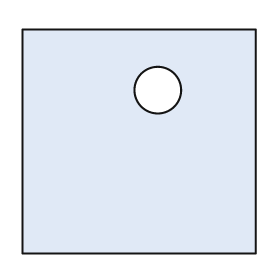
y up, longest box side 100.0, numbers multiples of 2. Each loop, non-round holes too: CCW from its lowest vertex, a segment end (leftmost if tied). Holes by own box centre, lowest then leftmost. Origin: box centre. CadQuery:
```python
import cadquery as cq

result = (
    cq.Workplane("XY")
    .moveTo(-50.0, -48.0)
    .lineTo(50.0, -48.0)
    .lineTo(50.0, 48.0)
    .lineTo(-50.0, 48.0)
    .close()
    .moveTo(8.0, 22.0)
    .circle(10.0)
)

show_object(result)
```